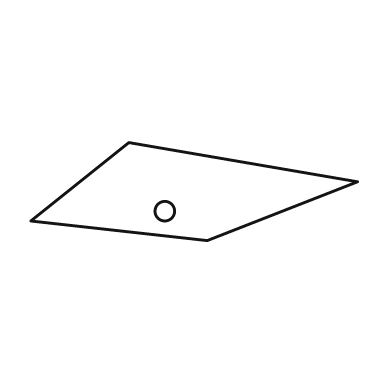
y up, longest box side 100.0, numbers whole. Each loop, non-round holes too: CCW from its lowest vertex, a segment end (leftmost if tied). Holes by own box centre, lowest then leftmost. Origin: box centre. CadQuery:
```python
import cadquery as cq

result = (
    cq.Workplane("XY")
    .moveTo(4.0, -15.0)
    .lineTo(50.0, 3.0)
    .lineTo(-20.0, 15.0)
    .lineTo(-50.0, -9.0)
    .close()
    .moveTo(-9.0, -6.0)
    .circle(3.0)
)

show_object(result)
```